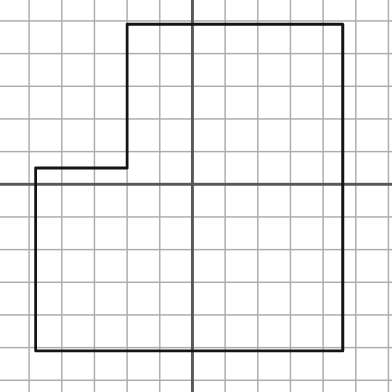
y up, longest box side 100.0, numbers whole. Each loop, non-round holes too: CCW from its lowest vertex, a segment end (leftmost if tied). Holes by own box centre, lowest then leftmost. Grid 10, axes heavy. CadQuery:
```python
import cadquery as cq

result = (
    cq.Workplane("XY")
    .moveTo(-48.0, -51.0)
    .lineTo(46.0, -51.0)
    .lineTo(46.0, 49.0)
    .lineTo(-20.0, 49.0)
    .lineTo(-20.0, 5.0)
    .lineTo(-48.0, 5.0)
    .close()
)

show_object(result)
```